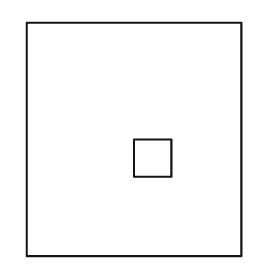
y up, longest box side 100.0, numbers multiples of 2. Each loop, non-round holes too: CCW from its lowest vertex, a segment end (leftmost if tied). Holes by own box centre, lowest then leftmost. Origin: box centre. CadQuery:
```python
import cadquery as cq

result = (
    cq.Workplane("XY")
    .moveTo(-46.0, -50.0)
    .lineTo(46.0, -50.0)
    .lineTo(46.0, 50.0)
    .lineTo(-46.0, 50.0)
    .close()
    .moveTo(0.0, -16.0)
    .lineTo(16.0, -16.0)
    .lineTo(16.0, 0.0)
    .lineTo(0.0, 0.0)
    .close()
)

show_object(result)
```